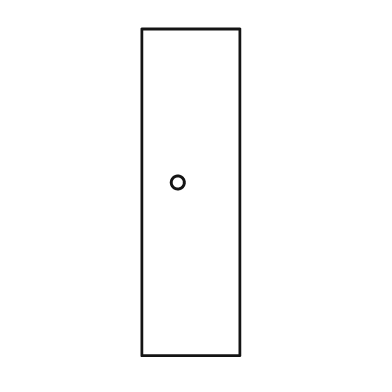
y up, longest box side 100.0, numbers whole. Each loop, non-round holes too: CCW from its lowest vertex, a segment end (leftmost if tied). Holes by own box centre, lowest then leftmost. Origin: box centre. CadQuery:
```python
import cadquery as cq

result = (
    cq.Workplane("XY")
    .moveTo(-15.0, -50.0)
    .lineTo(15.0, -50.0)
    .lineTo(15.0, 50.0)
    .lineTo(-15.0, 50.0)
    .close()
    .moveTo(-4.0, 3.0)
    .circle(2.0)
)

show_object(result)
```